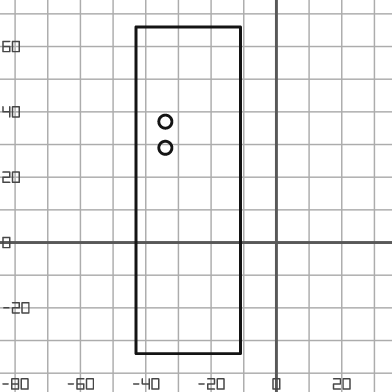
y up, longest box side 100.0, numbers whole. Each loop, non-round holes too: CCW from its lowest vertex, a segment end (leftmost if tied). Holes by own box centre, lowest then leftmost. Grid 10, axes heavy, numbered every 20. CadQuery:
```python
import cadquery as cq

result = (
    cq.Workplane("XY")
    .moveTo(-43.0, -34.0)
    .lineTo(-11.0, -34.0)
    .lineTo(-11.0, 66.0)
    .lineTo(-43.0, 66.0)
    .close()
    .moveTo(-34.0, 29.0)
    .circle(2.0)
    .moveTo(-34.0, 37.0)
    .circle(2.0)
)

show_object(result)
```